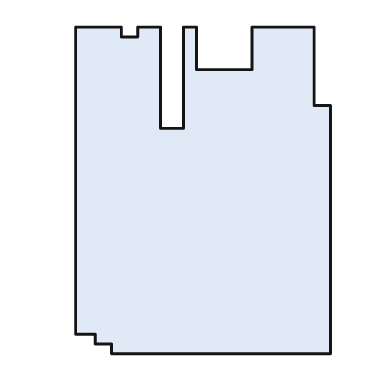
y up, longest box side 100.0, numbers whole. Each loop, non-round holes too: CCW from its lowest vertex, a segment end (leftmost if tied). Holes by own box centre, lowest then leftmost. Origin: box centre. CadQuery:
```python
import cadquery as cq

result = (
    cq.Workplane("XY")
    .moveTo(-28.0, -50.0)
    .lineTo(39.0, -50.0)
    .lineTo(39.0, 26.0)
    .lineTo(34.0, 26.0)
    .lineTo(34.0, 50.0)
    .lineTo(15.0, 50.0)
    .lineTo(15.0, 37.0)
    .lineTo(-2.0, 37.0)
    .lineTo(-2.0, 50.0)
    .lineTo(-6.0, 50.0)
    .lineTo(-6.0, 19.0)
    .lineTo(-13.0, 19.0)
    .lineTo(-13.0, 50.0)
    .lineTo(-20.0, 50.0)
    .lineTo(-20.0, 47.0)
    .lineTo(-25.0, 47.0)
    .lineTo(-25.0, 50.0)
    .lineTo(-39.0, 50.0)
    .lineTo(-39.0, -44.0)
    .lineTo(-33.0, -44.0)
    .lineTo(-33.0, -47.0)
    .lineTo(-28.0, -47.0)
    .close()
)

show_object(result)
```